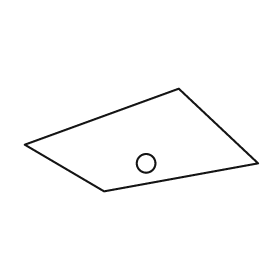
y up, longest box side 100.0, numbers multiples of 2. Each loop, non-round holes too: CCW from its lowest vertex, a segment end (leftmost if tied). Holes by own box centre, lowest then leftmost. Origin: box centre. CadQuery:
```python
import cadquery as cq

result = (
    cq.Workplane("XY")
    .moveTo(-16.0, -22.0)
    .lineTo(50.0, -10.0)
    .lineTo(16.0, 22.0)
    .lineTo(-50.0, -2.0)
    .close()
    .moveTo(2.0, -10.0)
    .circle(4.0)
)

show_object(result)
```